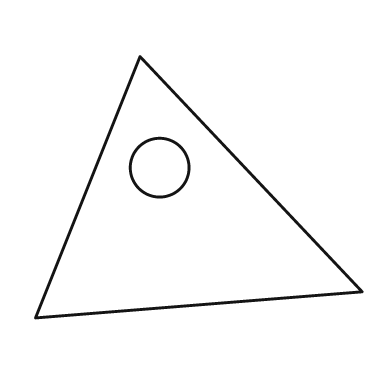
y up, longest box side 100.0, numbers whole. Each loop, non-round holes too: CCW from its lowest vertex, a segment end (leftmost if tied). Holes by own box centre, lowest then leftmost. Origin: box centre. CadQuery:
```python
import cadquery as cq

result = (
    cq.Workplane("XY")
    .moveTo(-50.0, -40.0)
    .lineTo(50.0, -32.0)
    .lineTo(-18.0, 40.0)
    .close()
    .moveTo(-12.0, 6.0)
    .circle(9.0)
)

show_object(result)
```